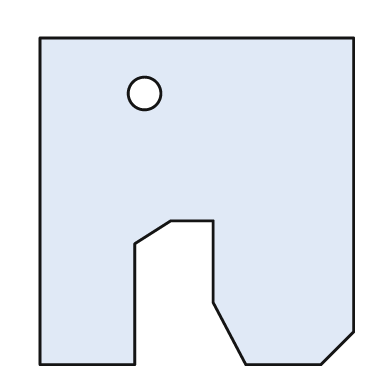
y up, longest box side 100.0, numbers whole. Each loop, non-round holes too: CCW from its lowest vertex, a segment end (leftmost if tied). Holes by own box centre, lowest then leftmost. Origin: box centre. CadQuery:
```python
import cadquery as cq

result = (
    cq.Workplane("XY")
    .moveTo(-48.0, -50.0)
    .lineTo(-19.0, -50.0)
    .lineTo(-19.0, -13.0)
    .lineTo(-8.0, -6.0)
    .lineTo(5.0, -6.0)
    .lineTo(5.0, -31.0)
    .lineTo(15.0, -50.0)
    .lineTo(38.0, -50.0)
    .lineTo(48.0, -40.0)
    .lineTo(48.0, 50.0)
    .lineTo(-48.0, 50.0)
    .close()
    .moveTo(-16.0, 33.0)
    .circle(5.0)
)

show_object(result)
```